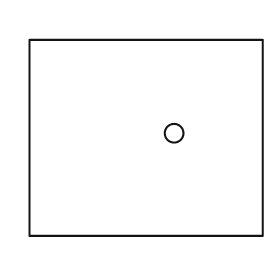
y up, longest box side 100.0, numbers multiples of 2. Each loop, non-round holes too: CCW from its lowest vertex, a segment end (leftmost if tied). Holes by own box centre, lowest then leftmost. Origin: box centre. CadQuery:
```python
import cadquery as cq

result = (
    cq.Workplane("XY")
    .moveTo(-50.0, -42.0)
    .lineTo(50.0, -42.0)
    .lineTo(50.0, 42.0)
    .lineTo(-50.0, 42.0)
    .close()
    .moveTo(12.0, 2.0)
    .circle(4.0)
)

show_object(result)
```